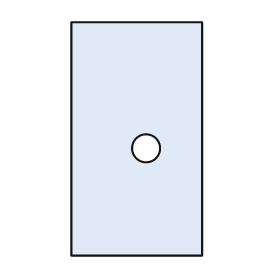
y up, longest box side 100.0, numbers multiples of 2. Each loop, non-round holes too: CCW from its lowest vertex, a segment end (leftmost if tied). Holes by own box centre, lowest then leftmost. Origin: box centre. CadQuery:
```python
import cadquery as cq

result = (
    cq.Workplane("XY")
    .moveTo(-28.0, -50.0)
    .lineTo(28.0, -50.0)
    .lineTo(28.0, 50.0)
    .lineTo(-28.0, 50.0)
    .close()
    .moveTo(4.0, -4.0)
    .circle(6.0)
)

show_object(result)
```